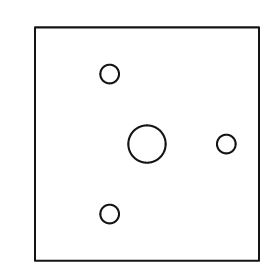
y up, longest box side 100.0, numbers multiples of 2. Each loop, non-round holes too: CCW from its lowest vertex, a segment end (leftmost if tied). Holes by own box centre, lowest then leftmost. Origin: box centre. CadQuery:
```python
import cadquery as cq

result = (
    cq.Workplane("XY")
    .moveTo(-48.0, -50.0)
    .lineTo(48.0, -50.0)
    .lineTo(48.0, 50.0)
    .lineTo(-48.0, 50.0)
    .close()
    .moveTo(-16.0, -30.0)
    .circle(4.0)
    .moveTo(0.0, 0.0)
    .circle(8.0)
    .moveTo(34.0, 0.0)
    .circle(4.0)
    .moveTo(-16.0, 30.0)
    .circle(4.0)
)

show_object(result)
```